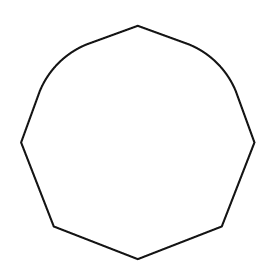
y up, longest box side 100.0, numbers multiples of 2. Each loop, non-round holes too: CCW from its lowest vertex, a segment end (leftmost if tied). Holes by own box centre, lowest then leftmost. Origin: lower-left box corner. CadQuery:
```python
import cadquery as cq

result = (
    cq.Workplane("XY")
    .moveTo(50.0, 0.0)
    .lineTo(86.0, 14.0)
    .lineTo(100.0, 50.0)
    .lineTo(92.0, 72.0)
    .threePointArc((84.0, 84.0), (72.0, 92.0))
    .lineTo(50.0, 100.0)
    .lineTo(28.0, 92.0)
    .threePointArc((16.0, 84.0), (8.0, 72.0))
    .lineTo(0.0, 50.0)
    .lineTo(14.0, 14.0)
    .close()
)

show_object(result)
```